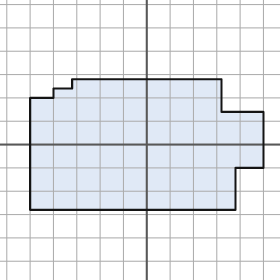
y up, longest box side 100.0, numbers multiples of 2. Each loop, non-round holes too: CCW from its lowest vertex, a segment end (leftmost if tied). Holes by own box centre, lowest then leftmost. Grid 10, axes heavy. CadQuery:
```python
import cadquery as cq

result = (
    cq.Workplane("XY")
    .moveTo(-50.0, -28.0)
    .lineTo(38.0, -28.0)
    .lineTo(38.0, -10.0)
    .lineTo(50.0, -10.0)
    .lineTo(50.0, 14.0)
    .lineTo(32.0, 14.0)
    .lineTo(32.0, 28.0)
    .lineTo(-32.0, 28.0)
    .lineTo(-32.0, 24.0)
    .lineTo(-40.0, 24.0)
    .lineTo(-40.0, 20.0)
    .lineTo(-50.0, 20.0)
    .close()
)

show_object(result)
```